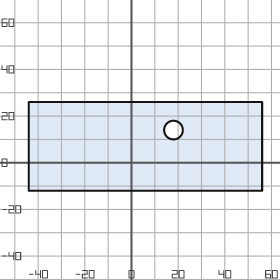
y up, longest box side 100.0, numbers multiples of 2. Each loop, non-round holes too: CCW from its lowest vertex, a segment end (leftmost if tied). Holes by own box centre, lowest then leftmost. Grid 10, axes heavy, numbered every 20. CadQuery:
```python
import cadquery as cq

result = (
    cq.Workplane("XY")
    .moveTo(-44.0, -12.0)
    .lineTo(56.0, -12.0)
    .lineTo(56.0, 26.0)
    .lineTo(-44.0, 26.0)
    .close()
    .moveTo(18.0, 14.0)
    .circle(4.0)
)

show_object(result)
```